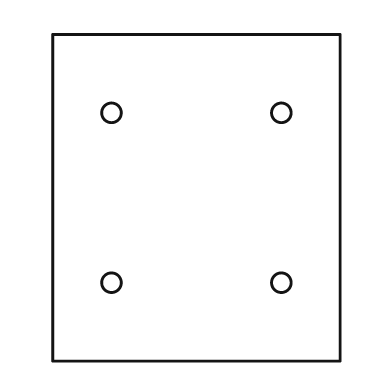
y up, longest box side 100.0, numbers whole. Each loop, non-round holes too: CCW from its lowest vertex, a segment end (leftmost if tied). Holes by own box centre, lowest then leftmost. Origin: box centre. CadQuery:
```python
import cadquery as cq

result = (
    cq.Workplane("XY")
    .moveTo(-44.0, -50.0)
    .lineTo(44.0, -50.0)
    .lineTo(44.0, 50.0)
    .lineTo(-44.0, 50.0)
    .close()
    .moveTo(-26.0, -26.0)
    .circle(3.0)
    .moveTo(26.0, -26.0)
    .circle(3.0)
    .moveTo(-26.0, 26.0)
    .circle(3.0)
    .moveTo(26.0, 26.0)
    .circle(3.0)
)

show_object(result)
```